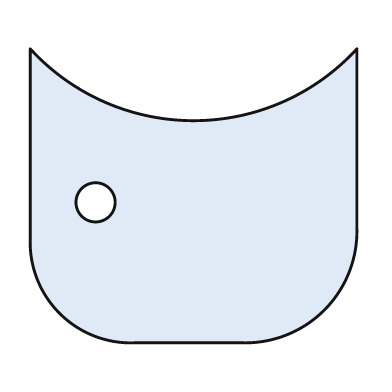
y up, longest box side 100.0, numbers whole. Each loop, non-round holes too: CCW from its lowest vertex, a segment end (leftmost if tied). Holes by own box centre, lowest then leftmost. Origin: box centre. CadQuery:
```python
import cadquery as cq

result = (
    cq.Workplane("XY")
    .moveTo(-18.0, -45.0)
    .lineTo(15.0, -45.0)
    .threePointArc((40.0, -35.0), (50.0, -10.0))
    .lineTo(50.0, 45.0)
    .threePointArc((0.0, 23.0), (-50.0, 45.0))
    .lineTo(-50.0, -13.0)
    .threePointArc((-41.0, -36.0), (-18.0, -45.0))
    .close()
    .moveTo(-30.0, -2.0)
    .circle(6.0)
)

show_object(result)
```